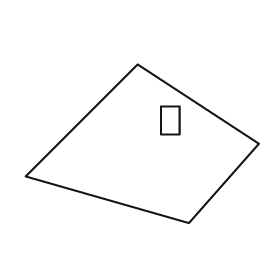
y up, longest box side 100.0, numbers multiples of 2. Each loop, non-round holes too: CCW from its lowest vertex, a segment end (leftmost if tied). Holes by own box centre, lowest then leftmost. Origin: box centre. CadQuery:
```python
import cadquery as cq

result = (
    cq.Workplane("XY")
    .moveTo(20.0, -34.0)
    .lineTo(50.0, 0.0)
    .lineTo(-2.0, 34.0)
    .lineTo(-50.0, -14.0)
    .close()
    .moveTo(8.0, 4.0)
    .lineTo(16.0, 4.0)
    .lineTo(16.0, 16.0)
    .lineTo(8.0, 16.0)
    .close()
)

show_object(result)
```